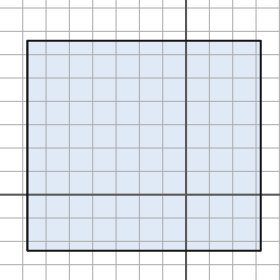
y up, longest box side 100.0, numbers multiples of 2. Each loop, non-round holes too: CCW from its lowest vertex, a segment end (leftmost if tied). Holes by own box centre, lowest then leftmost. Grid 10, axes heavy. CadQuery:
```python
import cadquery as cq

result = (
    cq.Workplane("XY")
    .moveTo(-68.0, -24.0)
    .lineTo(32.0, -24.0)
    .lineTo(32.0, 66.0)
    .lineTo(-68.0, 66.0)
    .close()
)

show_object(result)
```